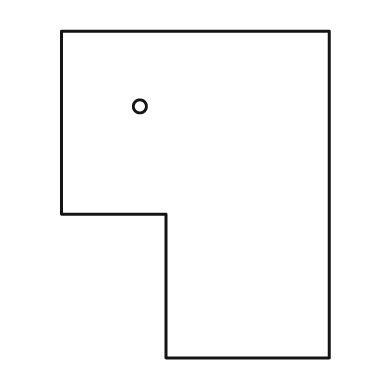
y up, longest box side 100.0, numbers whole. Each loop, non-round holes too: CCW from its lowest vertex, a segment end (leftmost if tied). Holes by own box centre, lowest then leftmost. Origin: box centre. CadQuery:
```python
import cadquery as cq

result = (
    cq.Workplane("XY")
    .moveTo(-9.0, -50.0)
    .lineTo(41.0, -50.0)
    .lineTo(41.0, 50.0)
    .lineTo(-41.0, 50.0)
    .lineTo(-41.0, -6.0)
    .lineTo(-9.0, -6.0)
    .close()
    .moveTo(-17.0, 27.0)
    .circle(2.0)
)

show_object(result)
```